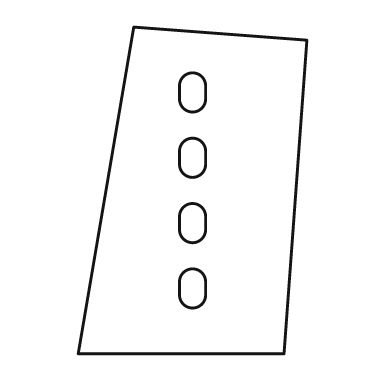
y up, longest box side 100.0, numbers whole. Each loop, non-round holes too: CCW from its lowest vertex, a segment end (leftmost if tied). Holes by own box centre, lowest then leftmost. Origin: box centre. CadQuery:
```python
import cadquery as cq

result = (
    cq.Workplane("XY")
    .moveTo(-35.0, -50.0)
    .lineTo(28.0, -50.0)
    .lineTo(35.0, 46.0)
    .lineTo(-18.0, 50.0)
    .close()
    .moveTo(-4.0, -32.0)
    .threePointArc((0.0, -36.0), (4.0, -32.0))
    .lineTo(4.0, -28.0)
    .threePointArc((0.0, -24.0), (-4.0, -28.0))
    .close()
    .moveTo(-4.0, -12.0)
    .threePointArc((0.0, -16.0), (4.0, -12.0))
    .lineTo(4.0, -8.0)
    .threePointArc((0.0, -4.0), (-4.0, -8.0))
    .close()
    .moveTo(-4.0, 8.0)
    .threePointArc((0.0, 4.0), (4.0, 8.0))
    .lineTo(4.0, 12.0)
    .threePointArc((0.0, 16.0), (-4.0, 12.0))
    .close()
    .moveTo(-4.0, 28.0)
    .threePointArc((0.0, 24.0), (4.0, 28.0))
    .lineTo(4.0, 32.0)
    .threePointArc((0.0, 36.0), (-4.0, 32.0))
    .close()
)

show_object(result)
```